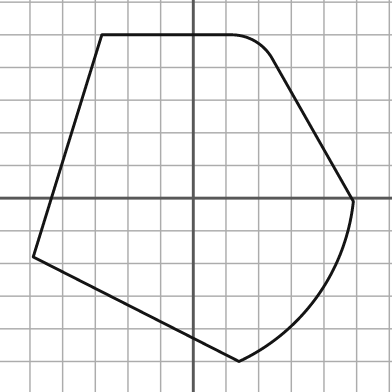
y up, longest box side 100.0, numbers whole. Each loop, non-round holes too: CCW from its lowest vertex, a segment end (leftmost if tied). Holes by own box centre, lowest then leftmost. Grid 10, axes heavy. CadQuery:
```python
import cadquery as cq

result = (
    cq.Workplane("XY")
    .moveTo(14.0, -50.0)
    .threePointArc((38.0, -30.0), (49.0, -1.0))
    .lineTo(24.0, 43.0)
    .threePointArc((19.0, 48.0), (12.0, 50.0))
    .lineTo(-28.0, 50.0)
    .lineTo(-49.0, -18.0)
    .close()
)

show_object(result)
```